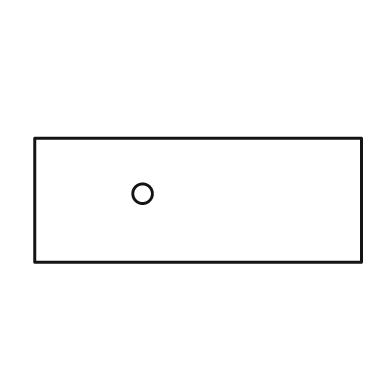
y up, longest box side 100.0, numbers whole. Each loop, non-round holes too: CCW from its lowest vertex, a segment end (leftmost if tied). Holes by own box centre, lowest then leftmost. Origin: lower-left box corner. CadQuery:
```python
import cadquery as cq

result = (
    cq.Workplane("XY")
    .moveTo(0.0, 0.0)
    .lineTo(100.0, 0.0)
    .lineTo(100.0, 38.0)
    .lineTo(0.0, 38.0)
    .close()
    .moveTo(33.0, 21.0)
    .circle(3.0)
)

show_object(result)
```